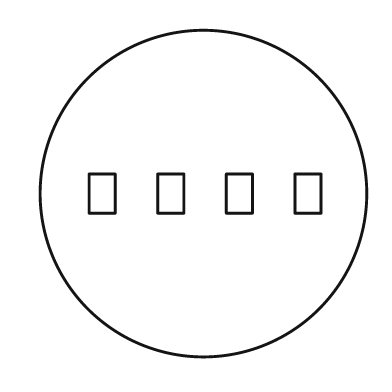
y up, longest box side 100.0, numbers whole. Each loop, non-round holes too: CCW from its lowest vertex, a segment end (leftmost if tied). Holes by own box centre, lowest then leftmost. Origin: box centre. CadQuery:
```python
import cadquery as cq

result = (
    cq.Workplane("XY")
    .moveTo(0.0, 0.0)
    .circle(50.0)
    .moveTo(-35.0, -6.0)
    .lineTo(-27.0, -6.0)
    .lineTo(-27.0, 6.0)
    .lineTo(-35.0, 6.0)
    .close()
    .moveTo(-14.0, -6.0)
    .lineTo(-6.0, -6.0)
    .lineTo(-6.0, 6.0)
    .lineTo(-14.0, 6.0)
    .close()
    .moveTo(7.0, -6.0)
    .lineTo(15.0, -6.0)
    .lineTo(15.0, 6.0)
    .lineTo(7.0, 6.0)
    .close()
    .moveTo(28.0, -6.0)
    .lineTo(36.0, -6.0)
    .lineTo(36.0, 6.0)
    .lineTo(28.0, 6.0)
    .close()
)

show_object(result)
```